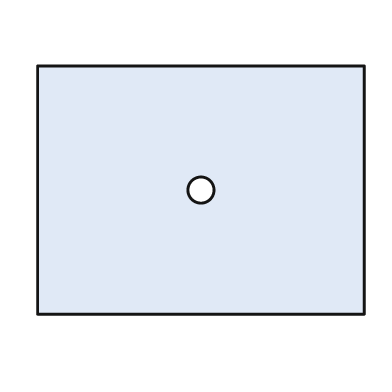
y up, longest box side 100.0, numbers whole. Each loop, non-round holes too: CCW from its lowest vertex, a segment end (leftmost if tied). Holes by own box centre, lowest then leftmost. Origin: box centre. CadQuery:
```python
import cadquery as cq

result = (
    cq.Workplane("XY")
    .moveTo(-50.0, -38.0)
    .lineTo(50.0, -38.0)
    .lineTo(50.0, 38.0)
    .lineTo(-50.0, 38.0)
    .close()
    .moveTo(0.0, 0.0)
    .circle(4.0)
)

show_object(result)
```